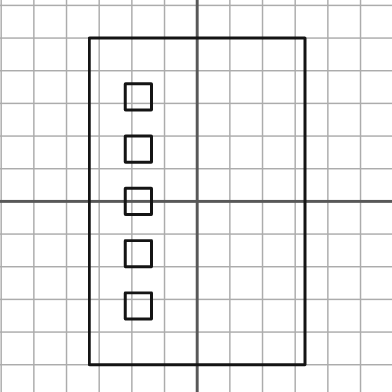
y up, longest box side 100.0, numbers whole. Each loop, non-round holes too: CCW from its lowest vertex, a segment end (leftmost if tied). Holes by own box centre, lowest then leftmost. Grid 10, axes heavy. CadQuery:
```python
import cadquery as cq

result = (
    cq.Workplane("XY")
    .moveTo(-33.0, -50.0)
    .lineTo(33.0, -50.0)
    .lineTo(33.0, 50.0)
    .lineTo(-33.0, 50.0)
    .close()
    .moveTo(-22.0, -36.0)
    .lineTo(-14.0, -36.0)
    .lineTo(-14.0, -28.0)
    .lineTo(-22.0, -28.0)
    .close()
    .moveTo(-22.0, -20.0)
    .lineTo(-14.0, -20.0)
    .lineTo(-14.0, -12.0)
    .lineTo(-22.0, -12.0)
    .close()
    .moveTo(-22.0, -4.0)
    .lineTo(-14.0, -4.0)
    .lineTo(-14.0, 4.0)
    .lineTo(-22.0, 4.0)
    .close()
    .moveTo(-22.0, 12.0)
    .lineTo(-14.0, 12.0)
    .lineTo(-14.0, 20.0)
    .lineTo(-22.0, 20.0)
    .close()
    .moveTo(-22.0, 28.0)
    .lineTo(-14.0, 28.0)
    .lineTo(-14.0, 36.0)
    .lineTo(-22.0, 36.0)
    .close()
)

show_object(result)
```